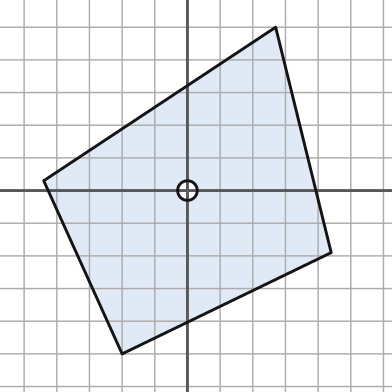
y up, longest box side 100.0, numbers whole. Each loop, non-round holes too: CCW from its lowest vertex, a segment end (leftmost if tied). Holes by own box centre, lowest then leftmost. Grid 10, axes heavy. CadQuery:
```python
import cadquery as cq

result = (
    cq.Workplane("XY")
    .moveTo(-20.0, -50.0)
    .lineTo(44.0, -19.0)
    .lineTo(27.0, 50.0)
    .lineTo(-44.0, 3.0)
    .close()
    .moveTo(0.0, 0.0)
    .circle(3.0)
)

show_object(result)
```